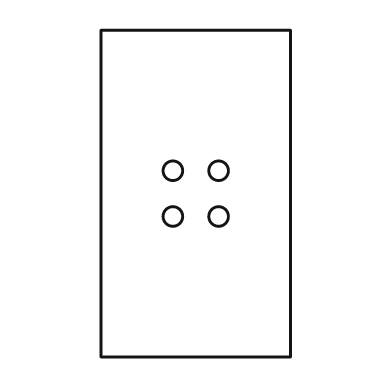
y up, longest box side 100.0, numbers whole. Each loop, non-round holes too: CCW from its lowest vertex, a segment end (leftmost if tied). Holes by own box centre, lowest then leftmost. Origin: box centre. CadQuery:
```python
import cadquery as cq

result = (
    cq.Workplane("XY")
    .moveTo(-29.0, -50.0)
    .lineTo(29.0, -50.0)
    .lineTo(29.0, 50.0)
    .lineTo(-29.0, 50.0)
    .close()
    .moveTo(-7.0, -7.0)
    .circle(3.0)
    .moveTo(7.0, -7.0)
    .circle(3.0)
    .moveTo(-7.0, 7.0)
    .circle(3.0)
    .moveTo(7.0, 7.0)
    .circle(3.0)
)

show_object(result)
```